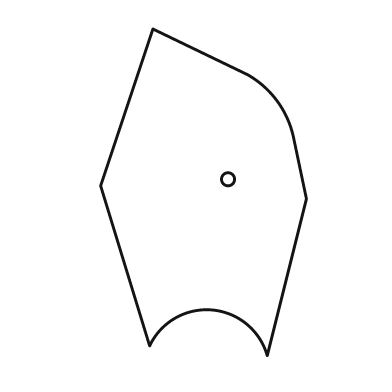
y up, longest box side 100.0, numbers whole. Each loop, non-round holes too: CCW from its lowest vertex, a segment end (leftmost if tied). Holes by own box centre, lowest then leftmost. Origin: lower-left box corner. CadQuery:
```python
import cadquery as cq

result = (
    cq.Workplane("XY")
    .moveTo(51.0, 0.0)
    .lineTo(63.0, 48.0)
    .lineTo(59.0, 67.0)
    .threePointArc((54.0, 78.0), (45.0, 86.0))
    .lineTo(16.0, 100.0)
    .lineTo(0.0, 52.0)
    .lineTo(15.0, 3.0)
    .threePointArc((34.0, 14.0), (51.0, 0.0))
    .close()
    .moveTo(39.0, 54.0)
    .circle(2.0)
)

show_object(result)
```